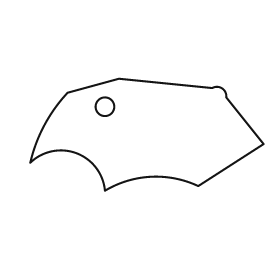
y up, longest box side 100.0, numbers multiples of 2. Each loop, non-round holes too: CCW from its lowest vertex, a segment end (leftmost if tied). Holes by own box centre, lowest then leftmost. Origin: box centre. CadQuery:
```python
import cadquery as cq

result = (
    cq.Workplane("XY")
    .moveTo(-18.0, -24.0)
    .threePointArc((2.0, -18.0), (22.0, -22.0))
    .lineTo(50.0, -4.0)
    .lineTo(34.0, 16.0)
    .threePointArc((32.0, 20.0), (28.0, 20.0))
    .lineTo(-12.0, 24.0)
    .lineTo(-34.0, 18.0)
    .threePointArc((-44.0, 4.0), (-50.0, -12.0))
    .threePointArc((-30.0, -8.0), (-18.0, -24.0))
    .close()
    .moveTo(-18.0, 12.0)
    .circle(4.0)
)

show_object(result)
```